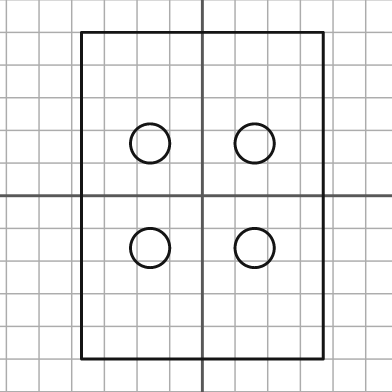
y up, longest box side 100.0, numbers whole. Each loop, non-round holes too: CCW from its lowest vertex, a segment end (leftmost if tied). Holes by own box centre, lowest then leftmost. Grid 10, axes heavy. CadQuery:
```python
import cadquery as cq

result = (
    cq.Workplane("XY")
    .moveTo(-37.0, -50.0)
    .lineTo(37.0, -50.0)
    .lineTo(37.0, 50.0)
    .lineTo(-37.0, 50.0)
    .close()
    .moveTo(-16.0, -16.0)
    .circle(6.0)
    .moveTo(16.0, -16.0)
    .circle(6.0)
    .moveTo(-16.0, 16.0)
    .circle(6.0)
    .moveTo(16.0, 16.0)
    .circle(6.0)
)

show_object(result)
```